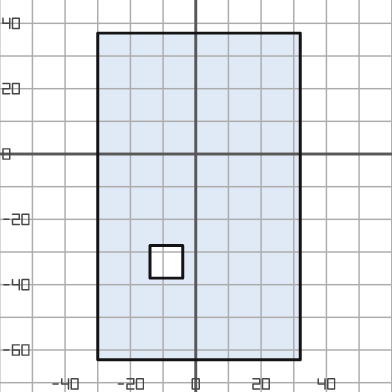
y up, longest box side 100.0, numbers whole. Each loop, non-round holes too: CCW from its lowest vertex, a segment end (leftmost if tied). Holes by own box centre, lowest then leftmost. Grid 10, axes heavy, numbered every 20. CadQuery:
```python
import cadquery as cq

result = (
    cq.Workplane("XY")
    .moveTo(-30.0, -63.0)
    .lineTo(32.0, -63.0)
    .lineTo(32.0, 37.0)
    .lineTo(-30.0, 37.0)
    .close()
    .moveTo(-14.0, -38.0)
    .lineTo(-4.0, -38.0)
    .lineTo(-4.0, -28.0)
    .lineTo(-14.0, -28.0)
    .close()
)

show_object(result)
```